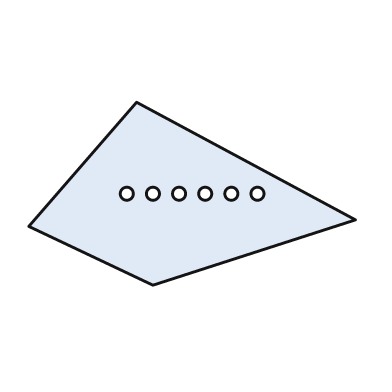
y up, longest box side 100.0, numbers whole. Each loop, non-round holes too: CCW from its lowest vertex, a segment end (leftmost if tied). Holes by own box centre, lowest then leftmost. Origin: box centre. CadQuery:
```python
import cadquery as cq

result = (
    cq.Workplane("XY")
    .moveTo(-12.0, -28.0)
    .lineTo(50.0, -8.0)
    .lineTo(-17.0, 28.0)
    .lineTo(-50.0, -10.0)
    .close()
    .moveTo(-20.0, 0.0)
    .circle(2.0)
    .moveTo(-12.0, 0.0)
    .circle(2.0)
    .moveTo(-4.0, 0.0)
    .circle(2.0)
    .moveTo(4.0, 0.0)
    .circle(2.0)
    .moveTo(12.0, 0.0)
    .circle(2.0)
    .moveTo(20.0, 0.0)
    .circle(2.0)
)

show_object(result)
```